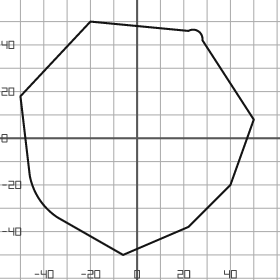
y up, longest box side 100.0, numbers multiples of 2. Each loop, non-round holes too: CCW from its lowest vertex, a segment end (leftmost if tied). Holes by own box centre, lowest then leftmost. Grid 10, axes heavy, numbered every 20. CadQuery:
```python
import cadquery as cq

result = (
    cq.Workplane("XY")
    .moveTo(-6.0, -50.0)
    .lineTo(22.0, -38.0)
    .lineTo(40.0, -20.0)
    .lineTo(50.0, 8.0)
    .lineTo(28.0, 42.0)
    .threePointArc((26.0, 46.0), (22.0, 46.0))
    .lineTo(-20.0, 50.0)
    .lineTo(-50.0, 18.0)
    .lineTo(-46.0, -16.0)
    .threePointArc((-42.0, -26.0), (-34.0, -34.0))
    .close()
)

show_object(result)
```